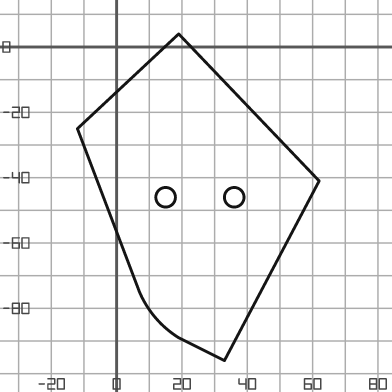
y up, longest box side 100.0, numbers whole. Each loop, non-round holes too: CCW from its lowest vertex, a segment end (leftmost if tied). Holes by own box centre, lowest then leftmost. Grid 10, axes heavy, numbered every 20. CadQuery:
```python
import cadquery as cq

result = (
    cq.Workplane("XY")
    .moveTo(33.0, -96.0)
    .lineTo(62.0, -41.0)
    .lineTo(19.0, 4.0)
    .lineTo(-12.0, -25.0)
    .lineTo(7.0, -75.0)
    .threePointArc((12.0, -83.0), (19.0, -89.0))
    .close()
    .moveTo(15.0, -46.0)
    .circle(3.0)
    .moveTo(36.0, -46.0)
    .circle(3.0)
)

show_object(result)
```